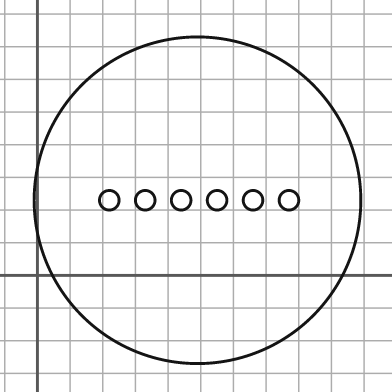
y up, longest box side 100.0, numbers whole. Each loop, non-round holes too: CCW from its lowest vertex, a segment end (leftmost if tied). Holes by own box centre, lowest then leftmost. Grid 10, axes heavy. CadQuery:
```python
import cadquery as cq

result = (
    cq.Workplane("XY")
    .moveTo(49.0, 23.0)
    .circle(50.0)
    .moveTo(22.0, 23.0)
    .circle(3.0)
    .moveTo(33.0, 23.0)
    .circle(3.0)
    .moveTo(44.0, 23.0)
    .circle(3.0)
    .moveTo(55.0, 23.0)
    .circle(3.0)
    .moveTo(66.0, 23.0)
    .circle(3.0)
    .moveTo(77.0, 23.0)
    .circle(3.0)
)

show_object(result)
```